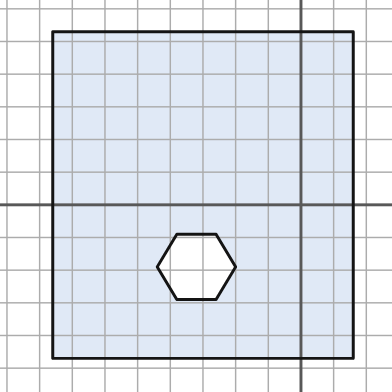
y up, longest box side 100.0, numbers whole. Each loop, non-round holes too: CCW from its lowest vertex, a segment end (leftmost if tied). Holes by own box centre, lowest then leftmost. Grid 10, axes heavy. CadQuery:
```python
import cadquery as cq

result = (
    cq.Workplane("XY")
    .moveTo(-76.0, -47.0)
    .lineTo(16.0, -47.0)
    .lineTo(16.0, 53.0)
    .lineTo(-76.0, 53.0)
    .close()
    .moveTo(-38.0, -29.0)
    .lineTo(-26.0, -29.0)
    .lineTo(-20.0, -19.0)
    .lineTo(-26.0, -9.0)
    .lineTo(-38.0, -9.0)
    .lineTo(-44.0, -19.0)
    .close()
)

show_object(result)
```